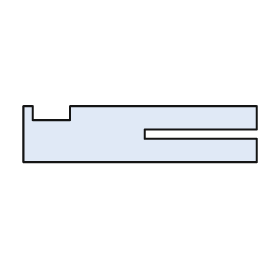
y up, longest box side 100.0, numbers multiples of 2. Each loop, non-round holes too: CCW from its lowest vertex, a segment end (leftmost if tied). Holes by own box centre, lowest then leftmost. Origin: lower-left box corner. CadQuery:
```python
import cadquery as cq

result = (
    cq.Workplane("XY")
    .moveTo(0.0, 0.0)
    .lineTo(100.0, 0.0)
    .lineTo(100.0, 10.0)
    .lineTo(52.0, 10.0)
    .lineTo(52.0, 14.0)
    .lineTo(100.0, 14.0)
    .lineTo(100.0, 24.0)
    .lineTo(20.0, 24.0)
    .lineTo(20.0, 18.0)
    .lineTo(4.0, 18.0)
    .lineTo(4.0, 24.0)
    .lineTo(0.0, 24.0)
    .close()
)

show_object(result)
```